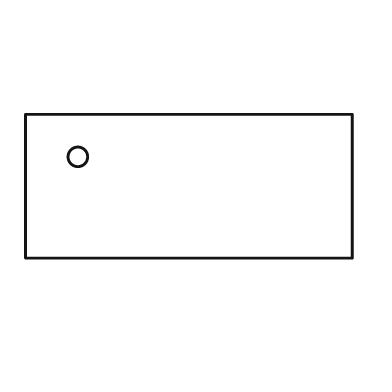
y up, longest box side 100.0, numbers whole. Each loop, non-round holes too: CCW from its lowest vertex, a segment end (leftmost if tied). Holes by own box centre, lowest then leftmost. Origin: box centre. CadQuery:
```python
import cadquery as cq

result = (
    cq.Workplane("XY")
    .moveTo(-50.0, -22.0)
    .lineTo(50.0, -22.0)
    .lineTo(50.0, 22.0)
    .lineTo(-50.0, 22.0)
    .close()
    .moveTo(-34.0, 9.0)
    .circle(3.0)
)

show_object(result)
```